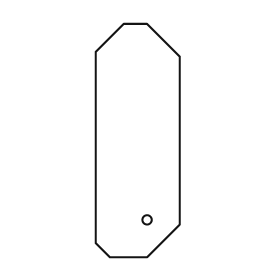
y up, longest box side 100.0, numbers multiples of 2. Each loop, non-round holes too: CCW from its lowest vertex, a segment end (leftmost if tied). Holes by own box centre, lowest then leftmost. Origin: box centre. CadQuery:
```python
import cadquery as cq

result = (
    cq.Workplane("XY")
    .moveTo(-12.0, -50.0)
    .lineTo(4.0, -50.0)
    .lineTo(18.0, -36.0)
    .lineTo(18.0, 36.0)
    .lineTo(4.0, 50.0)
    .lineTo(-6.0, 50.0)
    .lineTo(-18.0, 38.0)
    .lineTo(-18.0, -44.0)
    .close()
    .moveTo(4.0, -34.0)
    .circle(2.0)
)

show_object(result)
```